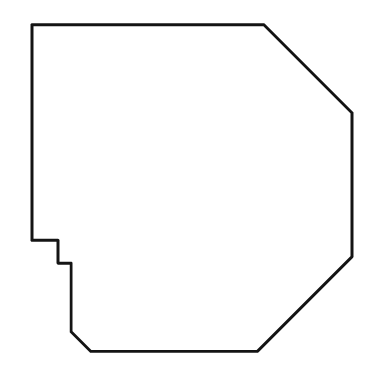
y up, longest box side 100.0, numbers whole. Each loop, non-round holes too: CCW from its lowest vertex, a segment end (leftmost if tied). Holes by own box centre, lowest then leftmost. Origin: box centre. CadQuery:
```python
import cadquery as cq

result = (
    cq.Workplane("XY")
    .moveTo(-31.0, -50.0)
    .lineTo(20.0, -50.0)
    .lineTo(49.0, -21.0)
    .lineTo(49.0, 23.0)
    .lineTo(22.0, 50.0)
    .lineTo(-49.0, 50.0)
    .lineTo(-49.0, -16.0)
    .lineTo(-41.0, -16.0)
    .lineTo(-41.0, -23.0)
    .lineTo(-37.0, -23.0)
    .lineTo(-37.0, -44.0)
    .close()
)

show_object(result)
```